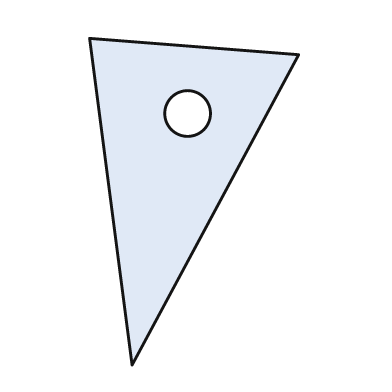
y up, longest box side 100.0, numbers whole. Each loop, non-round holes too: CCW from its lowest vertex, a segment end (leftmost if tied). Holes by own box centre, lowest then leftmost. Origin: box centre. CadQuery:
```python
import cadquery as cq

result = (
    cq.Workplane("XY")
    .moveTo(-19.0, -50.0)
    .lineTo(32.0, 45.0)
    .lineTo(-32.0, 50.0)
    .close()
    .moveTo(-2.0, 27.0)
    .circle(7.0)
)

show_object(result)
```